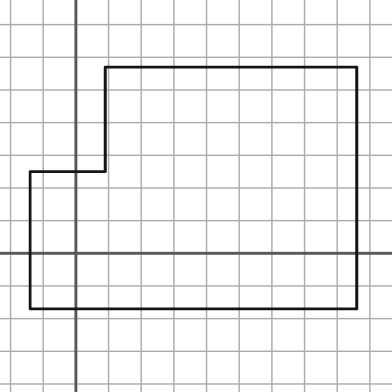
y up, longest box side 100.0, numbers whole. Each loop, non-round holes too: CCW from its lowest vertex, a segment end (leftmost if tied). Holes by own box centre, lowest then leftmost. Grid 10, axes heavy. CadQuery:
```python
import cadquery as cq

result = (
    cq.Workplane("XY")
    .moveTo(-14.0, -17.0)
    .lineTo(86.0, -17.0)
    .lineTo(86.0, 57.0)
    .lineTo(9.0, 57.0)
    .lineTo(9.0, 25.0)
    .lineTo(-14.0, 25.0)
    .close()
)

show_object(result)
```